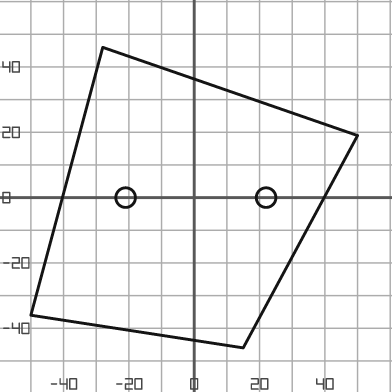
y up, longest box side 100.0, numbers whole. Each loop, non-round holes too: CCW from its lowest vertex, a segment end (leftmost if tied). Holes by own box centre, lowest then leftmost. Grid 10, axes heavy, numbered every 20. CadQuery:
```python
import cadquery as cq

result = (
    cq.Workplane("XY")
    .moveTo(15.0, -46.0)
    .lineTo(50.0, 19.0)
    .lineTo(-28.0, 46.0)
    .lineTo(-50.0, -36.0)
    .close()
    .moveTo(-21.0, 0.0)
    .circle(3.0)
    .moveTo(22.0, 0.0)
    .circle(3.0)
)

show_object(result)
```